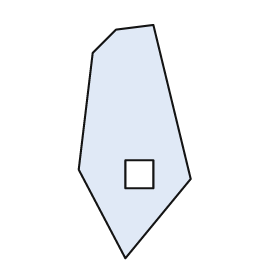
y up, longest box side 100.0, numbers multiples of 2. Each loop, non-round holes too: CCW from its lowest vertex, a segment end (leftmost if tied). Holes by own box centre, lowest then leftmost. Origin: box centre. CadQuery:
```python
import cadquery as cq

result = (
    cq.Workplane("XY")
    .moveTo(-4.0, -50.0)
    .lineTo(24.0, -16.0)
    .lineTo(8.0, 50.0)
    .lineTo(-8.0, 48.0)
    .lineTo(-18.0, 38.0)
    .lineTo(-24.0, -12.0)
    .close()
    .moveTo(-4.0, -20.0)
    .lineTo(8.0, -20.0)
    .lineTo(8.0, -8.0)
    .lineTo(-4.0, -8.0)
    .close()
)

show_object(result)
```